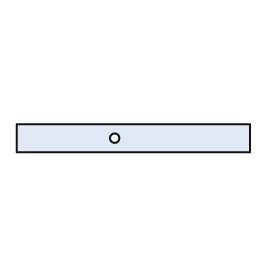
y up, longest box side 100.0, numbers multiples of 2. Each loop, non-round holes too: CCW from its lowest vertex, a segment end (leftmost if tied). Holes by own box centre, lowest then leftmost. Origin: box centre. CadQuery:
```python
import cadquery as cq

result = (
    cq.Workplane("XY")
    .moveTo(-50.0, -6.0)
    .lineTo(50.0, -6.0)
    .lineTo(50.0, 6.0)
    .lineTo(-50.0, 6.0)
    .close()
    .moveTo(-8.0, 0.0)
    .circle(2.0)
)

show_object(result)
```